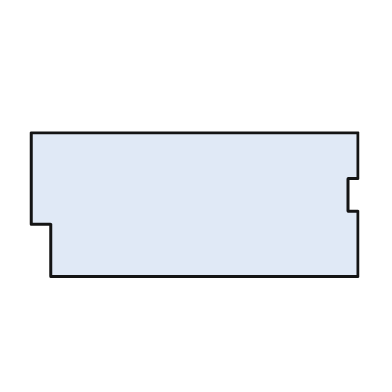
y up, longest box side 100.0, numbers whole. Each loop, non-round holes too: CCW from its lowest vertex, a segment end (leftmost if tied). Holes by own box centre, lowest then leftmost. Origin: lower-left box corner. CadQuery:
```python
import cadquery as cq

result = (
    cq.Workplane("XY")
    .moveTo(6.0, 0.0)
    .lineTo(100.0, 0.0)
    .lineTo(100.0, 20.0)
    .lineTo(97.0, 20.0)
    .lineTo(97.0, 30.0)
    .lineTo(100.0, 30.0)
    .lineTo(100.0, 44.0)
    .lineTo(0.0, 44.0)
    .lineTo(0.0, 16.0)
    .lineTo(6.0, 16.0)
    .close()
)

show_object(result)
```